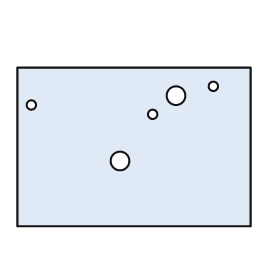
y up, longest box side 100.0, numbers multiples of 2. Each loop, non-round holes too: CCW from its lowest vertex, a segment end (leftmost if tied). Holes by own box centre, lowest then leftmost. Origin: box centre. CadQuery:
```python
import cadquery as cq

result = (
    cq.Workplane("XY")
    .moveTo(-50.0, -34.0)
    .lineTo(50.0, -34.0)
    .lineTo(50.0, 34.0)
    .lineTo(-50.0, 34.0)
    .close()
    .moveTo(-6.0, -6.0)
    .circle(4.0)
    .moveTo(8.0, 14.0)
    .circle(2.0)
    .moveTo(-44.0, 18.0)
    .circle(2.0)
    .moveTo(18.0, 22.0)
    .circle(4.0)
    .moveTo(34.0, 26.0)
    .circle(2.0)
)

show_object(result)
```